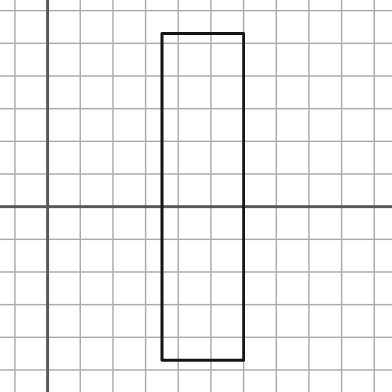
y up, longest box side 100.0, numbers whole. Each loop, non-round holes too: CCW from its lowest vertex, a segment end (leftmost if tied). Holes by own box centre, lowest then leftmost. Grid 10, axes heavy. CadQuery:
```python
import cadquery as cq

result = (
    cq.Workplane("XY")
    .moveTo(35.0, -47.0)
    .lineTo(60.0, -47.0)
    .lineTo(60.0, 53.0)
    .lineTo(35.0, 53.0)
    .close()
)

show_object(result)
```